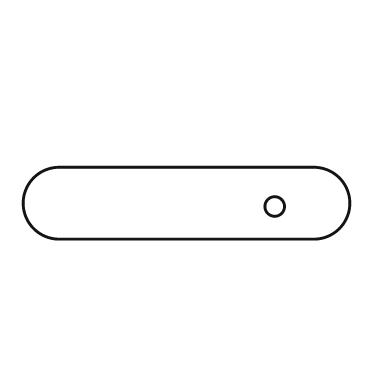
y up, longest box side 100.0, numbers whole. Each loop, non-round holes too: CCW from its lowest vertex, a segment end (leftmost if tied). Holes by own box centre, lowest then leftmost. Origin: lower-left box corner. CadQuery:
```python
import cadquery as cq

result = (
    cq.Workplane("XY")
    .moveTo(11.0, 0.0)
    .lineTo(89.0, 0.0)
    .threePointArc((100.0, 11.0), (89.0, 22.0))
    .lineTo(11.0, 22.0)
    .threePointArc((0.0, 11.0), (11.0, 0.0))
    .close()
    .moveTo(77.0, 10.0)
    .circle(3.0)
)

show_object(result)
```